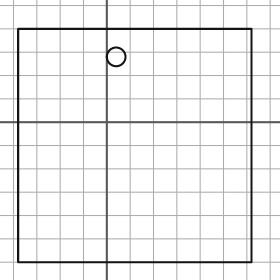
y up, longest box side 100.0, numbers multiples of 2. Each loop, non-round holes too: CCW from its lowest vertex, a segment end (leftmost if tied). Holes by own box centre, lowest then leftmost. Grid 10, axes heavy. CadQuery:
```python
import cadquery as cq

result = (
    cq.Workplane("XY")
    .moveTo(-38.0, -60.0)
    .lineTo(62.0, -60.0)
    .lineTo(62.0, 40.0)
    .lineTo(-38.0, 40.0)
    .close()
    .moveTo(4.0, 28.0)
    .circle(4.0)
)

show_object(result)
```